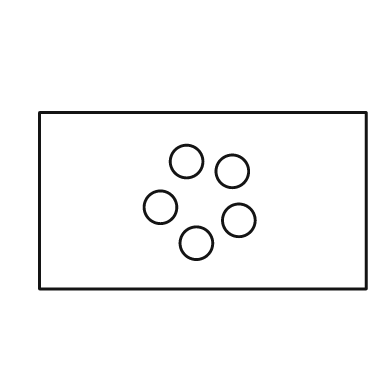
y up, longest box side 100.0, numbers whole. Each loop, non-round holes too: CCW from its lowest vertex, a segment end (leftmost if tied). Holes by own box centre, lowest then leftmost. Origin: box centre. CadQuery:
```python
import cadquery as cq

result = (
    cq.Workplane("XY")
    .moveTo(-50.0, -27.0)
    .lineTo(50.0, -27.0)
    .lineTo(50.0, 27.0)
    .lineTo(-50.0, 27.0)
    .close()
    .moveTo(-2.0, -13.0)
    .circle(5.0)
    .moveTo(11.0, -6.0)
    .circle(5.0)
    .moveTo(-13.0, -2.0)
    .circle(5.0)
    .moveTo(9.0, 9.0)
    .circle(5.0)
    .moveTo(-5.0, 12.0)
    .circle(5.0)
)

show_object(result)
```